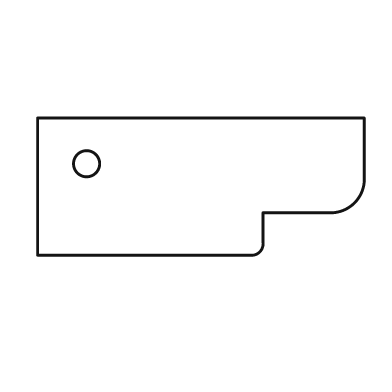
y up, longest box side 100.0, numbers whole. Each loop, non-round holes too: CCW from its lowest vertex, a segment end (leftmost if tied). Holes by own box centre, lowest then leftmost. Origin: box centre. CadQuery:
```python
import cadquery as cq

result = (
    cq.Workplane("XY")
    .moveTo(-50.0, -21.0)
    .lineTo(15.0, -21.0)
    .threePointArc((18.0, -20.0), (19.0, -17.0))
    .lineTo(19.0, -8.0)
    .lineTo(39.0, -8.0)
    .threePointArc((47.0, -5.0), (50.0, 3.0))
    .lineTo(50.0, 21.0)
    .lineTo(-50.0, 21.0)
    .close()
    .moveTo(-35.0, 7.0)
    .circle(4.0)
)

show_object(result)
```